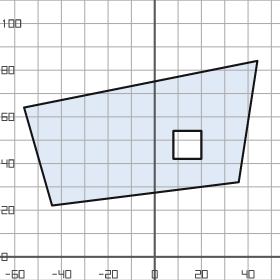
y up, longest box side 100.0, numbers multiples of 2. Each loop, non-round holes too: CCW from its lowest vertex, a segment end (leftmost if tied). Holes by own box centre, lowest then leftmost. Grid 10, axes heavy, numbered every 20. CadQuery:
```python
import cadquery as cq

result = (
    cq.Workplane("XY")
    .moveTo(-44.0, 22.0)
    .lineTo(36.0, 32.0)
    .lineTo(44.0, 84.0)
    .lineTo(-56.0, 64.0)
    .close()
    .moveTo(8.0, 42.0)
    .lineTo(20.0, 42.0)
    .lineTo(20.0, 54.0)
    .lineTo(8.0, 54.0)
    .close()
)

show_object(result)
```